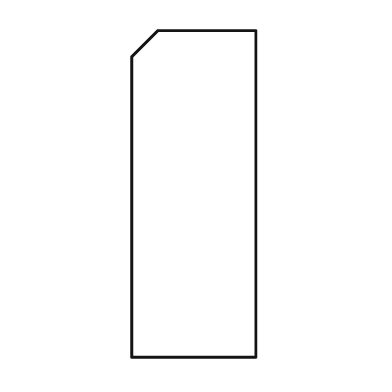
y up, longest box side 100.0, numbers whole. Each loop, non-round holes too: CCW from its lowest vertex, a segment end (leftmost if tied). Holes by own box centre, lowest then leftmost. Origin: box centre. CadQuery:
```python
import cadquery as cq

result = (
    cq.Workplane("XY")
    .moveTo(-19.0, -50.0)
    .lineTo(19.0, -50.0)
    .lineTo(19.0, 50.0)
    .lineTo(-11.0, 50.0)
    .lineTo(-19.0, 42.0)
    .close()
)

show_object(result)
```